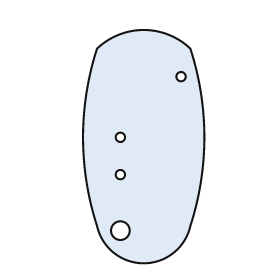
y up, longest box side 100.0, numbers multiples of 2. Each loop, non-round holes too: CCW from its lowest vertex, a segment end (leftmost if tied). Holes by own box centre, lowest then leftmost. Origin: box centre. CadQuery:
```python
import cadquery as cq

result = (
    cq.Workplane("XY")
    .moveTo(-20.0, -34.0)
    .threePointArc((0.0, -50.0), (20.0, -34.0))
    .threePointArc((26.0, 4.0), (20.0, 42.0))
    .threePointArc((0.0, 50.0), (-20.0, 42.0))
    .threePointArc((-26.0, 4.0), (-20.0, -34.0))
    .close()
    .moveTo(-10.0, -36.0)
    .circle(4.0)
    .moveTo(-10.0, -12.0)
    .circle(2.0)
    .moveTo(-10.0, 4.0)
    .circle(2.0)
    .moveTo(16.0, 30.0)
    .circle(2.0)
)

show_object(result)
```